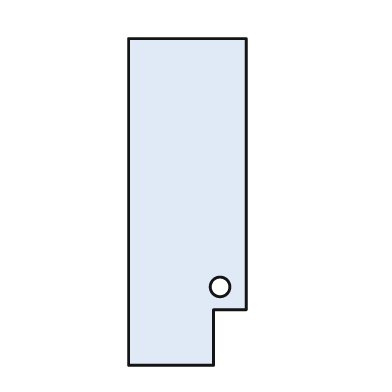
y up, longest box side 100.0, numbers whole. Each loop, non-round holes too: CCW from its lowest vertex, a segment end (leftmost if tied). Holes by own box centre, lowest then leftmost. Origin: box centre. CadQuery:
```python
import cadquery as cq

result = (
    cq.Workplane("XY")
    .moveTo(-18.0, -50.0)
    .lineTo(8.0, -50.0)
    .lineTo(8.0, -33.0)
    .lineTo(18.0, -33.0)
    .lineTo(18.0, 50.0)
    .lineTo(-18.0, 50.0)
    .close()
    .moveTo(10.0, -26.0)
    .circle(3.0)
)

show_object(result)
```